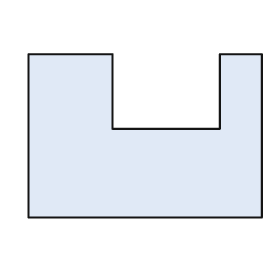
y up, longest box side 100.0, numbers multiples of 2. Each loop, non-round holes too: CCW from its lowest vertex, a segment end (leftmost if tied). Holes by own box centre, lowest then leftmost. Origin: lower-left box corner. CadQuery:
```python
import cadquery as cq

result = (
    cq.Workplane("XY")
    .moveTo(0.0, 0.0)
    .lineTo(100.0, 0.0)
    .lineTo(100.0, 70.0)
    .lineTo(82.0, 70.0)
    .lineTo(82.0, 38.0)
    .lineTo(36.0, 38.0)
    .lineTo(36.0, 70.0)
    .lineTo(0.0, 70.0)
    .close()
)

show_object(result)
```